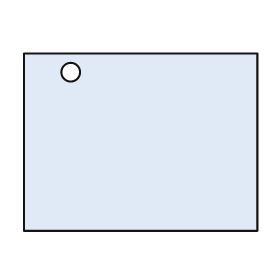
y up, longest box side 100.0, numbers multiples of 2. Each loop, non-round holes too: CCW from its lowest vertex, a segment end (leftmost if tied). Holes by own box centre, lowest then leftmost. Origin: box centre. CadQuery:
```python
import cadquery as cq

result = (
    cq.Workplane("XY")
    .moveTo(-50.0, -38.0)
    .lineTo(50.0, -38.0)
    .lineTo(50.0, 38.0)
    .lineTo(-50.0, 38.0)
    .close()
    .moveTo(-30.0, 30.0)
    .circle(4.0)
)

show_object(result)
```